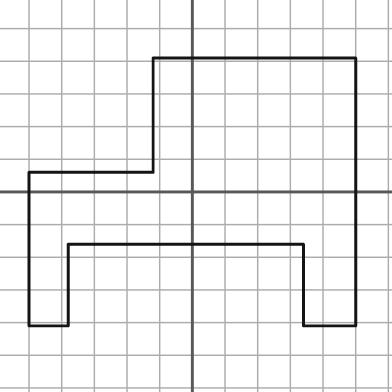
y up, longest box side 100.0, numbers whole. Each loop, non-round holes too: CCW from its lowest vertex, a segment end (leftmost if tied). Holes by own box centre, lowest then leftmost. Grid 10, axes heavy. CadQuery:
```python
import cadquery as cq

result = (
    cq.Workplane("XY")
    .moveTo(-50.0, -41.0)
    .lineTo(-38.0, -41.0)
    .lineTo(-38.0, -16.0)
    .lineTo(34.0, -16.0)
    .lineTo(34.0, -41.0)
    .lineTo(50.0, -41.0)
    .lineTo(50.0, 41.0)
    .lineTo(-12.0, 41.0)
    .lineTo(-12.0, 6.0)
    .lineTo(-50.0, 6.0)
    .close()
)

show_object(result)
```